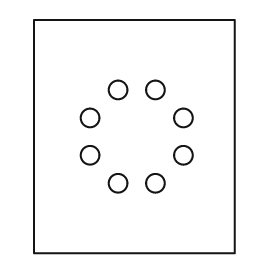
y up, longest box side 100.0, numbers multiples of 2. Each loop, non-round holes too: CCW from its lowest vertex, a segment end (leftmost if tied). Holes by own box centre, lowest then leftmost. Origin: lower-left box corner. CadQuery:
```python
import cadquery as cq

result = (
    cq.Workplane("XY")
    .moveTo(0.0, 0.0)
    .lineTo(86.0, 0.0)
    .lineTo(86.0, 100.0)
    .lineTo(0.0, 100.0)
    .close()
    .moveTo(36.0, 30.0)
    .circle(4.0)
    .moveTo(52.0, 30.0)
    .circle(4.0)
    .moveTo(24.0, 42.0)
    .circle(4.0)
    .moveTo(64.0, 42.0)
    .circle(4.0)
    .moveTo(24.0, 58.0)
    .circle(4.0)
    .moveTo(64.0, 58.0)
    .circle(4.0)
    .moveTo(36.0, 70.0)
    .circle(4.0)
    .moveTo(52.0, 70.0)
    .circle(4.0)
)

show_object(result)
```